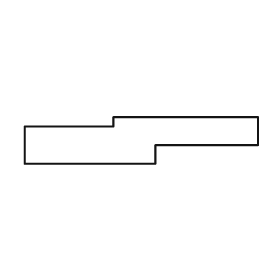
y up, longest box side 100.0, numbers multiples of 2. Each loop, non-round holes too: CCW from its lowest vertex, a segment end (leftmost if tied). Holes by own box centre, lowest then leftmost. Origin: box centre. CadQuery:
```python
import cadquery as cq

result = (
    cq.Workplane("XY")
    .moveTo(-50.0, -10.0)
    .lineTo(6.0, -10.0)
    .lineTo(6.0, -2.0)
    .lineTo(50.0, -2.0)
    .lineTo(50.0, 10.0)
    .lineTo(-12.0, 10.0)
    .lineTo(-12.0, 6.0)
    .lineTo(-50.0, 6.0)
    .close()
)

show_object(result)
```